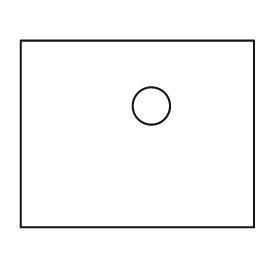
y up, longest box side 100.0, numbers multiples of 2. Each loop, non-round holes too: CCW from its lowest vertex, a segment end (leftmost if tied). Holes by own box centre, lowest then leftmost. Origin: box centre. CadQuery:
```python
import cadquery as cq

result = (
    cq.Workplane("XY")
    .moveTo(-50.0, -40.0)
    .lineTo(50.0, -40.0)
    .lineTo(50.0, 40.0)
    .lineTo(-50.0, 40.0)
    .close()
    .moveTo(6.0, 12.0)
    .circle(8.0)
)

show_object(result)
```